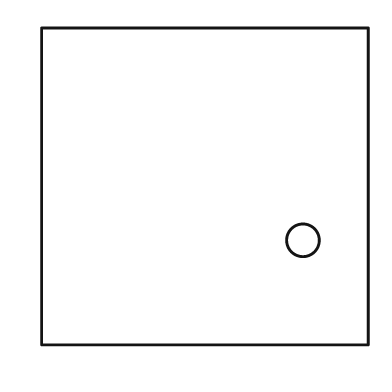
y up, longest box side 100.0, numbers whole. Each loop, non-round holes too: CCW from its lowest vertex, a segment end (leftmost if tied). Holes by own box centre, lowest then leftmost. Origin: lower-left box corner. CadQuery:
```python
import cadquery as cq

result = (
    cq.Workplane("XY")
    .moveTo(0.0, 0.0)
    .lineTo(100.0, 0.0)
    .lineTo(100.0, 97.0)
    .lineTo(0.0, 97.0)
    .close()
    .moveTo(80.0, 32.0)
    .circle(5.0)
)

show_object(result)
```